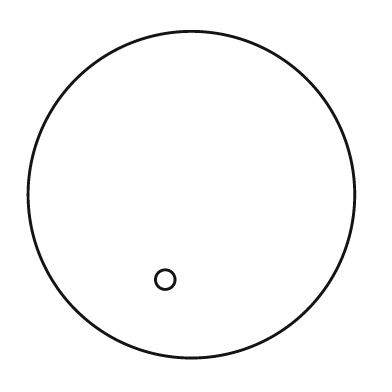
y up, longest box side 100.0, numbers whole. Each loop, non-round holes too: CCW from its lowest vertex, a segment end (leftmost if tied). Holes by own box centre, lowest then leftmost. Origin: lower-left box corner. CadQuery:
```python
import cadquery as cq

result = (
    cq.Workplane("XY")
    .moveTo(50.0, 50.0)
    .circle(50.0)
    .moveTo(42.0, 24.0)
    .circle(3.0)
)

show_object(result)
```